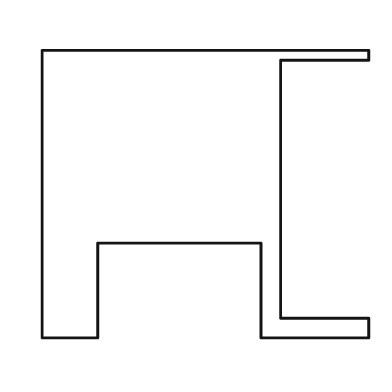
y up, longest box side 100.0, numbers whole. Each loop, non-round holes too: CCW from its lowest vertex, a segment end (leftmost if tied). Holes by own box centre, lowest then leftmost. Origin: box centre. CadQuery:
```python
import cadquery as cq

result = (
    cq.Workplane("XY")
    .moveTo(-50.0, -44.0)
    .lineTo(-33.0, -44.0)
    .lineTo(-33.0, -15.0)
    .lineTo(17.0, -15.0)
    .lineTo(17.0, -44.0)
    .lineTo(50.0, -44.0)
    .lineTo(50.0, -38.0)
    .lineTo(23.0, -38.0)
    .lineTo(23.0, 41.0)
    .lineTo(50.0, 41.0)
    .lineTo(50.0, 44.0)
    .lineTo(-50.0, 44.0)
    .close()
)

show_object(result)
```